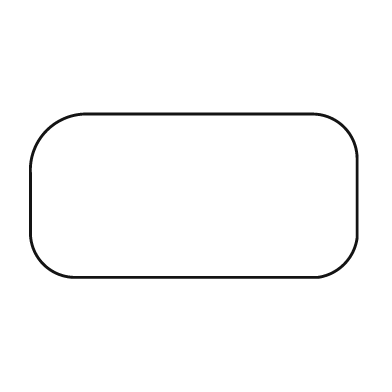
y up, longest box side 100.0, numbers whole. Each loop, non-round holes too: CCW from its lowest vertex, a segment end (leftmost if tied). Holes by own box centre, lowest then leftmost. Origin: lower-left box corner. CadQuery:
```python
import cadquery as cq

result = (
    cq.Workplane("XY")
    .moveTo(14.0, 0.0)
    .lineTo(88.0, 0.0)
    .threePointArc((96.0, 4.0), (100.0, 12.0))
    .lineTo(100.0, 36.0)
    .threePointArc((96.0, 46.0), (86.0, 50.0))
    .lineTo(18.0, 50.0)
    .threePointArc((5.0, 45.0), (0.0, 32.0))
    .lineTo(0.0, 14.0)
    .threePointArc((4.0, 4.0), (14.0, 0.0))
    .close()
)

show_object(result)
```